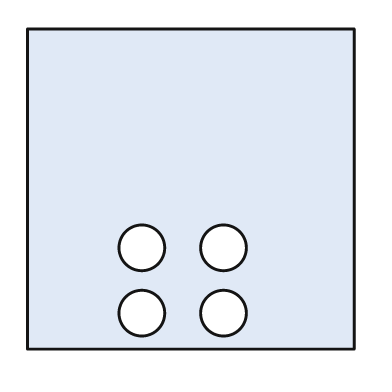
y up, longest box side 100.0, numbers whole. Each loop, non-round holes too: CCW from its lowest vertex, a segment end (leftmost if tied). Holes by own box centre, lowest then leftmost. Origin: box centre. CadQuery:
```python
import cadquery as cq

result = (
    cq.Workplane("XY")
    .moveTo(-50.0, -49.0)
    .lineTo(50.0, -49.0)
    .lineTo(50.0, 49.0)
    .lineTo(-50.0, 49.0)
    .close()
    .moveTo(-15.0, -38.0)
    .circle(7.0)
    .moveTo(10.0, -38.0)
    .circle(7.0)
    .moveTo(-15.0, -18.0)
    .circle(7.0)
    .moveTo(10.0, -18.0)
    .circle(7.0)
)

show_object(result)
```